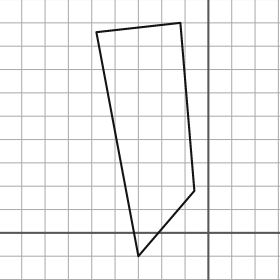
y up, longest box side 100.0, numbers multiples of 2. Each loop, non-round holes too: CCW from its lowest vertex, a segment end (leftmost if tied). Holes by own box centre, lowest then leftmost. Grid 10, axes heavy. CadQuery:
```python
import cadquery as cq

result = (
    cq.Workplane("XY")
    .moveTo(-30.0, -10.0)
    .lineTo(-6.0, 18.0)
    .lineTo(-12.0, 90.0)
    .lineTo(-48.0, 86.0)
    .close()
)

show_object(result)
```